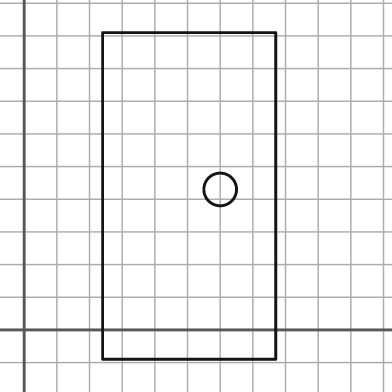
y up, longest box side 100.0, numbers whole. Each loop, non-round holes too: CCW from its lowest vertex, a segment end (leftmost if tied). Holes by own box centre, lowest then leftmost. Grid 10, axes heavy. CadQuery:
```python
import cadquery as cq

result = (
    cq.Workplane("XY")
    .moveTo(24.0, -9.0)
    .lineTo(77.0, -9.0)
    .lineTo(77.0, 91.0)
    .lineTo(24.0, 91.0)
    .close()
    .moveTo(60.0, 43.0)
    .circle(5.0)
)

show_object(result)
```